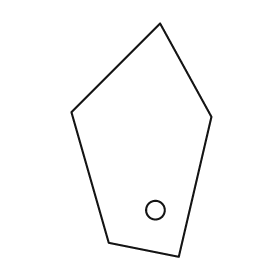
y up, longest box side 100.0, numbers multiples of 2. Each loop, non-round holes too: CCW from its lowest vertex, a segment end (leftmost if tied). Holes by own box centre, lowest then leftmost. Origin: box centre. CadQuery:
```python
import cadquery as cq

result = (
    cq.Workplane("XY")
    .moveTo(16.0, -50.0)
    .lineTo(30.0, 10.0)
    .lineTo(8.0, 50.0)
    .lineTo(-30.0, 12.0)
    .lineTo(-14.0, -44.0)
    .close()
    .moveTo(6.0, -30.0)
    .circle(4.0)
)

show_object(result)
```